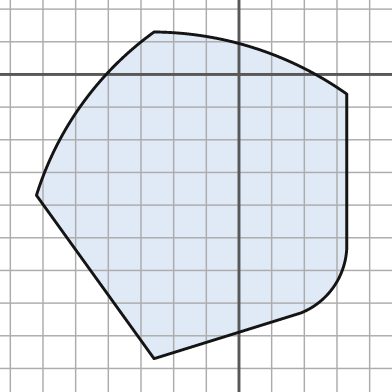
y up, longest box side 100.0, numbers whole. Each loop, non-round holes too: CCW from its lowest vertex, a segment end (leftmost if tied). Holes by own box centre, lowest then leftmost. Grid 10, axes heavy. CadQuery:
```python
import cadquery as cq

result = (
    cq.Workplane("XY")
    .moveTo(-26.0, -87.0)
    .lineTo(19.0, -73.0)
    .threePointArc((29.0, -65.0), (33.0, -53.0))
    .lineTo(33.0, -6.0)
    .threePointArc((5.0, 8.0), (-26.0, 13.0))
    .threePointArc((-48.0, -9.0), (-62.0, -37.0))
    .close()
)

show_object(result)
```